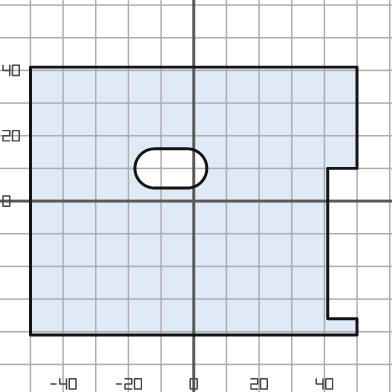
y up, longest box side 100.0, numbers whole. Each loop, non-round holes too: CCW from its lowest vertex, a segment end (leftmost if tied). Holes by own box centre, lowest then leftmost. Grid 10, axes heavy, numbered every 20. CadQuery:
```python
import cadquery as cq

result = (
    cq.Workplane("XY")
    .moveTo(-50.0, -41.0)
    .lineTo(50.0, -41.0)
    .lineTo(50.0, -36.0)
    .lineTo(41.0, -36.0)
    .lineTo(41.0, 10.0)
    .lineTo(50.0, 10.0)
    .lineTo(50.0, 41.0)
    .lineTo(-50.0, 41.0)
    .close()
    .moveTo(-12.0, 4.0)
    .lineTo(-2.0, 4.0)
    .threePointArc((4.0, 10.0), (-2.0, 16.0))
    .lineTo(-12.0, 16.0)
    .threePointArc((-18.0, 10.0), (-12.0, 4.0))
    .close()
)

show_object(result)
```